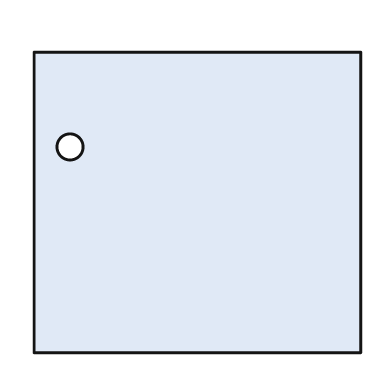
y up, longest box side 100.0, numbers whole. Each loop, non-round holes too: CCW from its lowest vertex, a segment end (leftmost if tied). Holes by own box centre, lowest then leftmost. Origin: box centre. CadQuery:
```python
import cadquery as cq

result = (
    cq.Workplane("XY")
    .moveTo(-50.0, -46.0)
    .lineTo(50.0, -46.0)
    .lineTo(50.0, 46.0)
    .lineTo(-50.0, 46.0)
    .close()
    .moveTo(-39.0, 17.0)
    .circle(4.0)
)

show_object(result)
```